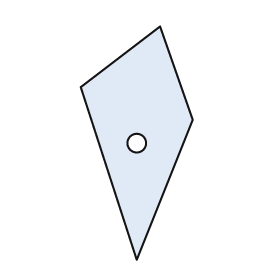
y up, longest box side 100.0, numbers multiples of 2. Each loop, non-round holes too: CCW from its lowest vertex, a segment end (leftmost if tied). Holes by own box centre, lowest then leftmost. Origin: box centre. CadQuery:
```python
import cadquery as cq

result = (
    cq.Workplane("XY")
    .moveTo(0.0, -50.0)
    .lineTo(24.0, 10.0)
    .lineTo(10.0, 50.0)
    .lineTo(-24.0, 24.0)
    .close()
    .moveTo(0.0, 0.0)
    .circle(4.0)
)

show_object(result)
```